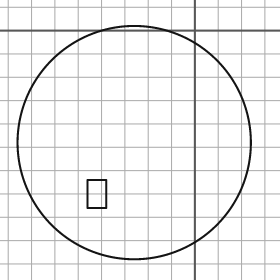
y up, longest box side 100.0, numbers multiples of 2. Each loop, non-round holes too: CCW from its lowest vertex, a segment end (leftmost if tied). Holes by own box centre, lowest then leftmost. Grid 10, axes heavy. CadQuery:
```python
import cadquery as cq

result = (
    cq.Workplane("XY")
    .moveTo(-26.0, -48.0)
    .circle(50.0)
    .moveTo(-46.0, -76.0)
    .lineTo(-38.0, -76.0)
    .lineTo(-38.0, -64.0)
    .lineTo(-46.0, -64.0)
    .close()
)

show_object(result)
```